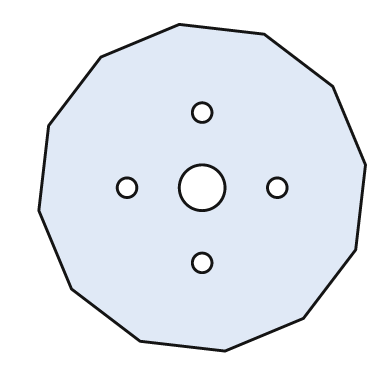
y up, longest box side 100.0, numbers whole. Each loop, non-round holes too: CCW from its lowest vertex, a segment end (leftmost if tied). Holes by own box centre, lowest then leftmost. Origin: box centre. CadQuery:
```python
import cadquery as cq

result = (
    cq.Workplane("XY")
    .moveTo(7.0, -50.0)
    .lineTo(31.0, -40.0)
    .lineTo(47.0, -19.0)
    .lineTo(50.0, 7.0)
    .lineTo(40.0, 31.0)
    .lineTo(19.0, 47.0)
    .lineTo(-7.0, 50.0)
    .lineTo(-31.0, 40.0)
    .lineTo(-47.0, 19.0)
    .lineTo(-50.0, -7.0)
    .lineTo(-40.0, -31.0)
    .lineTo(-19.0, -47.0)
    .close()
    .moveTo(0.0, -23.0)
    .circle(3.0)
    .moveTo(-23.0, 0.0)
    .circle(3.0)
    .moveTo(0.0, 0.0)
    .circle(7.0)
    .moveTo(23.0, 0.0)
    .circle(3.0)
    .moveTo(0.0, 23.0)
    .circle(3.0)
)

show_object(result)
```